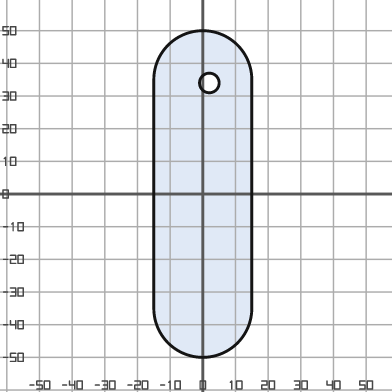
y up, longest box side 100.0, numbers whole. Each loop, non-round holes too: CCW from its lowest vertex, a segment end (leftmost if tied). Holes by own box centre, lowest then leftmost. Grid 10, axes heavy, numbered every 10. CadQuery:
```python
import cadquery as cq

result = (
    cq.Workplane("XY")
    .moveTo(-15.0, -35.0)
    .threePointArc((0.0, -50.0), (15.0, -35.0))
    .lineTo(15.0, 35.0)
    .threePointArc((0.0, 50.0), (-15.0, 35.0))
    .close()
    .moveTo(2.0, 34.0)
    .circle(3.0)
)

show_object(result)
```